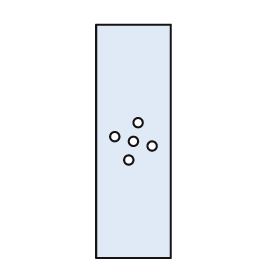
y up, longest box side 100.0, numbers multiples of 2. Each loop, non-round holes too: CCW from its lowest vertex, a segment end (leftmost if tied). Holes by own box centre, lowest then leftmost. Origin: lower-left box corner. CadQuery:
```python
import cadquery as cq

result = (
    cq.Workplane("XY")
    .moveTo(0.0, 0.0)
    .lineTo(32.0, 0.0)
    .lineTo(32.0, 100.0)
    .lineTo(0.0, 100.0)
    .close()
    .moveTo(14.0, 42.0)
    .circle(2.0)
    .moveTo(24.0, 48.0)
    .circle(2.0)
    .moveTo(16.0, 50.0)
    .circle(2.0)
    .moveTo(8.0, 52.0)
    .circle(2.0)
    .moveTo(18.0, 58.0)
    .circle(2.0)
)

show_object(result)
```